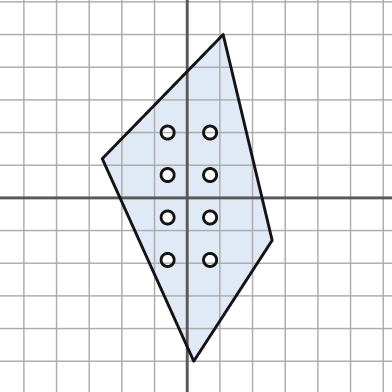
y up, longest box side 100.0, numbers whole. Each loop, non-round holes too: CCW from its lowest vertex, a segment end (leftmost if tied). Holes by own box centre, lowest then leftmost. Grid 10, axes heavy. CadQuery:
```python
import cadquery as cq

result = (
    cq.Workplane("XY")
    .moveTo(2.0, -50.0)
    .lineTo(26.0, -13.0)
    .lineTo(11.0, 50.0)
    .lineTo(-26.0, 12.0)
    .close()
    .moveTo(-6.0, -19.0)
    .circle(2.0)
    .moveTo(7.0, -19.0)
    .circle(2.0)
    .moveTo(-6.0, -6.0)
    .circle(2.0)
    .moveTo(7.0, -6.0)
    .circle(2.0)
    .moveTo(-6.0, 7.0)
    .circle(2.0)
    .moveTo(7.0, 7.0)
    .circle(2.0)
    .moveTo(-6.0, 20.0)
    .circle(2.0)
    .moveTo(7.0, 20.0)
    .circle(2.0)
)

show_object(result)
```